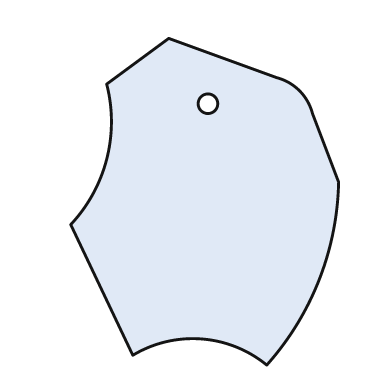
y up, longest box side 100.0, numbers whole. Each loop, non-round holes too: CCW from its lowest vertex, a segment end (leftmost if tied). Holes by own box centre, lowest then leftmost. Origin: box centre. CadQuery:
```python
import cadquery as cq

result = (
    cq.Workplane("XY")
    .moveTo(19.0, -50.0)
    .threePointArc((35.0, -24.0), (41.0, 6.0))
    .lineTo(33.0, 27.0)
    .threePointArc((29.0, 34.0), (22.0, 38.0))
    .lineTo(-11.0, 50.0)
    .lineTo(-30.0, 36.0)
    .threePointArc((-30.0, 13.0), (-41.0, -7.0))
    .lineTo(-22.0, -47.0)
    .threePointArc((-1.0, -42.0), (19.0, -50.0))
    .close()
    .moveTo(1.0, 30.0)
    .circle(3.0)
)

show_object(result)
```